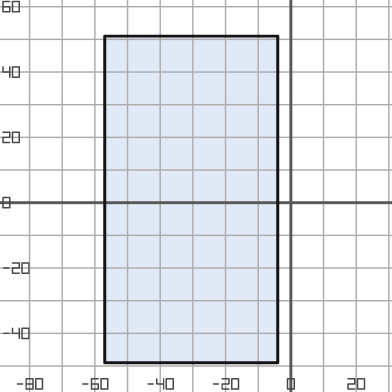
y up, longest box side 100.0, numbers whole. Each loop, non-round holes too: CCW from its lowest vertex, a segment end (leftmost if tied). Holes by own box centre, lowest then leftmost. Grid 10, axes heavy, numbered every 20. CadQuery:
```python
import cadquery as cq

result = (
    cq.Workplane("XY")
    .moveTo(-57.0, -49.0)
    .lineTo(-4.0, -49.0)
    .lineTo(-4.0, 51.0)
    .lineTo(-57.0, 51.0)
    .close()
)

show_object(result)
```